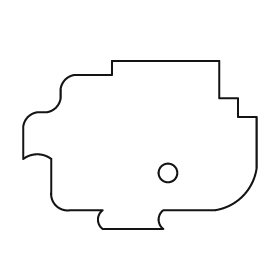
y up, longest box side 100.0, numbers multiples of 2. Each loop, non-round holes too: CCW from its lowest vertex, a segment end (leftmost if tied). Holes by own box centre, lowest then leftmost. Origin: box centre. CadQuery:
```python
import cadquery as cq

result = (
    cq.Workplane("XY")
    .moveTo(-16.0, -36.0)
    .lineTo(10.0, -36.0)
    .threePointArc((8.0, -32.0), (10.0, -28.0))
    .lineTo(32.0, -28.0)
    .threePointArc((44.0, -22.0), (50.0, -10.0))
    .lineTo(50.0, 12.0)
    .lineTo(42.0, 12.0)
    .lineTo(42.0, 20.0)
    .lineTo(34.0, 20.0)
    .lineTo(34.0, 36.0)
    .lineTo(-12.0, 36.0)
    .lineTo(-12.0, 30.0)
    .lineTo(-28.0, 30.0)
    .threePointArc((-32.0, 28.0), (-34.0, 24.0))
    .lineTo(-34.0, 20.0)
    .threePointArc((-36.0, 16.0), (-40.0, 14.0))
    .lineTo(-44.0, 14.0)
    .threePointArc((-48.0, 12.0), (-50.0, 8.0))
    .lineTo(-50.0, -6.0)
    .threePointArc((-44.0, -4.0), (-38.0, -6.0))
    .lineTo(-38.0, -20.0)
    .threePointArc((-36.0, -26.0), (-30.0, -28.0))
    .lineTo(-16.0, -28.0)
    .threePointArc((-18.0, -32.0), (-16.0, -36.0))
    .close()
    .moveTo(12.0, -12.0)
    .circle(4.0)
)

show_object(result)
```